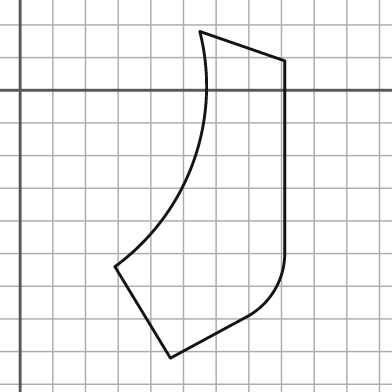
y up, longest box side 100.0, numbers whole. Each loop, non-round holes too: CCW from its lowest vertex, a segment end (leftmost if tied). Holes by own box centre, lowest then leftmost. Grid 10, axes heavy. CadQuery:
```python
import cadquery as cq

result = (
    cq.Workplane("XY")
    .moveTo(46.0, -82.0)
    .lineTo(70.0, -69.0)
    .threePointArc((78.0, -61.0), (81.0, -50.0))
    .lineTo(81.0, 9.0)
    .lineTo(55.0, 18.0)
    .threePointArc((53.0, -22.0), (29.0, -54.0))
    .close()
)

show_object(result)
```